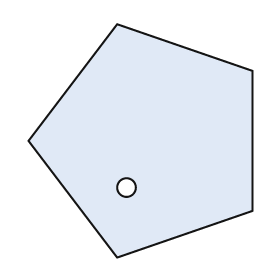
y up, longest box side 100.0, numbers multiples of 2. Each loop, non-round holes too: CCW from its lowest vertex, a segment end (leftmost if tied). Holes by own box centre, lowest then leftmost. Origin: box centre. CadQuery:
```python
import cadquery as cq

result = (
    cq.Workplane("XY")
    .moveTo(-10.0, -50.0)
    .lineTo(48.0, -30.0)
    .lineTo(48.0, 30.0)
    .lineTo(-10.0, 50.0)
    .lineTo(-48.0, 0.0)
    .close()
    .moveTo(-6.0, -20.0)
    .circle(4.0)
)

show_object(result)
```